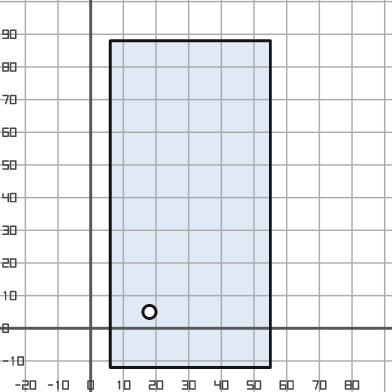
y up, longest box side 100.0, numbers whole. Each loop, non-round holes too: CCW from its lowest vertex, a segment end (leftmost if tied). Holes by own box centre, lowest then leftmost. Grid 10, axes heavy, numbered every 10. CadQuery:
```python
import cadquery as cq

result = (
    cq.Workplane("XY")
    .moveTo(6.0, -12.0)
    .lineTo(55.0, -12.0)
    .lineTo(55.0, 88.0)
    .lineTo(6.0, 88.0)
    .close()
    .moveTo(18.0, 5.0)
    .circle(2.0)
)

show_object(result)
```